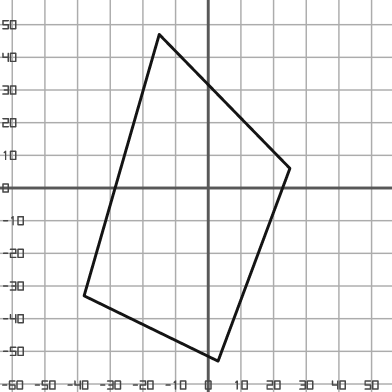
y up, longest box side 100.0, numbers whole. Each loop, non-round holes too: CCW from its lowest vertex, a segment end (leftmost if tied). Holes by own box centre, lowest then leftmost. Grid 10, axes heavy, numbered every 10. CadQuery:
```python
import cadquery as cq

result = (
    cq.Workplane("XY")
    .moveTo(3.0, -53.0)
    .lineTo(25.0, 6.0)
    .lineTo(-15.0, 47.0)
    .lineTo(-38.0, -33.0)
    .close()
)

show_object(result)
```